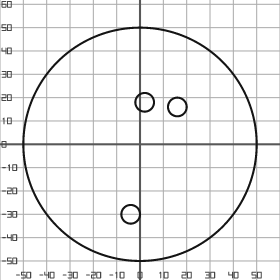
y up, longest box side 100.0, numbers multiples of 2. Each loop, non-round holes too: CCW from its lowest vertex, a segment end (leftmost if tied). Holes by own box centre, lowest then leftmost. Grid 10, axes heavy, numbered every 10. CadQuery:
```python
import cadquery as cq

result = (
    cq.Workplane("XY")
    .moveTo(0.0, 0.0)
    .circle(50.0)
    .moveTo(-4.0, -30.0)
    .circle(4.0)
    .moveTo(16.0, 16.0)
    .circle(4.0)
    .moveTo(2.0, 18.0)
    .circle(4.0)
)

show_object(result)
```